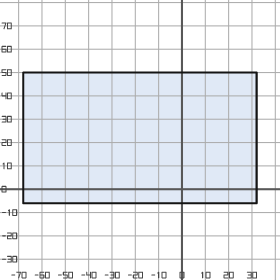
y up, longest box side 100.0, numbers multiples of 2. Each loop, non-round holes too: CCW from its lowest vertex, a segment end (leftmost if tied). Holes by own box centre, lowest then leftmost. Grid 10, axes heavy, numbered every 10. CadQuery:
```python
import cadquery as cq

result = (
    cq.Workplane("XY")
    .moveTo(-68.0, -6.0)
    .lineTo(32.0, -6.0)
    .lineTo(32.0, 50.0)
    .lineTo(-68.0, 50.0)
    .close()
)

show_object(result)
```